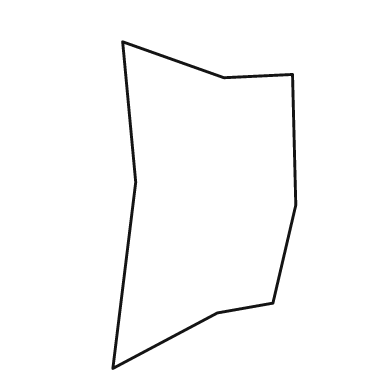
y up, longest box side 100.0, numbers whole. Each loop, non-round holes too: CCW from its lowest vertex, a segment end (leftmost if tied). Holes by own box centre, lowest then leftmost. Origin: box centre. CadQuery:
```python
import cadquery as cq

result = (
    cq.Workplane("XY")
    .moveTo(-28.0, -50.0)
    .lineTo(4.0, -33.0)
    .lineTo(21.0, -30.0)
    .lineTo(28.0, 0.0)
    .lineTo(27.0, 40.0)
    .lineTo(6.0, 39.0)
    .lineTo(-25.0, 50.0)
    .lineTo(-21.0, 7.0)
    .close()
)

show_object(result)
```